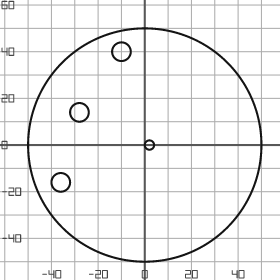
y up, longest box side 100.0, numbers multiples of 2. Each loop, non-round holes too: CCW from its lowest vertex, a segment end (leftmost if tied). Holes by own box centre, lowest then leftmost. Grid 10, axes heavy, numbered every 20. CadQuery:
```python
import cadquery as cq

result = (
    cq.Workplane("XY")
    .moveTo(0.0, 0.0)
    .circle(50.0)
    .moveTo(-36.0, -16.0)
    .circle(4.0)
    .moveTo(2.0, 0.0)
    .circle(2.0)
    .moveTo(-28.0, 14.0)
    .circle(4.0)
    .moveTo(-10.0, 40.0)
    .circle(4.0)
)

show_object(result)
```